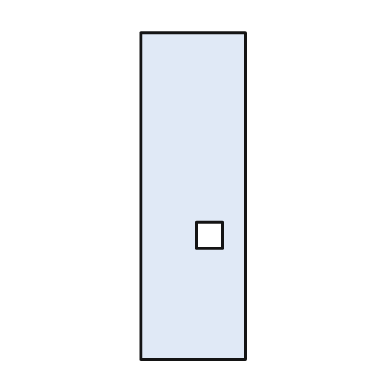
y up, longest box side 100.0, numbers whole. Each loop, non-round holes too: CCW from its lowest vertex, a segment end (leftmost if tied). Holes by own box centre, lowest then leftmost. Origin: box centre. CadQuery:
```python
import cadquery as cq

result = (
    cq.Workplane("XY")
    .moveTo(-16.0, -50.0)
    .lineTo(16.0, -50.0)
    .lineTo(16.0, 50.0)
    .lineTo(-16.0, 50.0)
    .close()
    .moveTo(1.0, -16.0)
    .lineTo(9.0, -16.0)
    .lineTo(9.0, -8.0)
    .lineTo(1.0, -8.0)
    .close()
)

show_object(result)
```